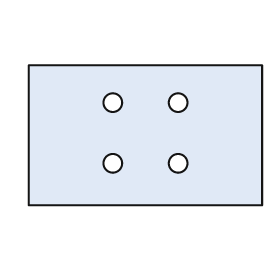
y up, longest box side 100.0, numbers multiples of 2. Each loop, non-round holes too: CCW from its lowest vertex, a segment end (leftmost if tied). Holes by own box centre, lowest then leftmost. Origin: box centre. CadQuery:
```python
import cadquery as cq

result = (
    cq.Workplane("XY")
    .moveTo(-50.0, -30.0)
    .lineTo(50.0, -30.0)
    .lineTo(50.0, 30.0)
    .lineTo(-50.0, 30.0)
    .close()
    .moveTo(-14.0, -12.0)
    .circle(4.0)
    .moveTo(14.0, -12.0)
    .circle(4.0)
    .moveTo(-14.0, 14.0)
    .circle(4.0)
    .moveTo(14.0, 14.0)
    .circle(4.0)
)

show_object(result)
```